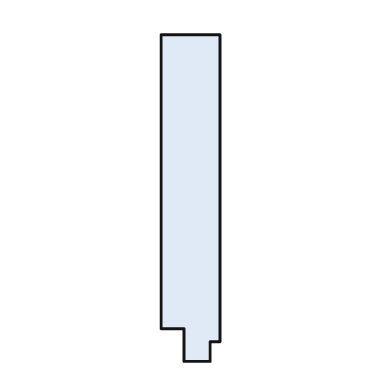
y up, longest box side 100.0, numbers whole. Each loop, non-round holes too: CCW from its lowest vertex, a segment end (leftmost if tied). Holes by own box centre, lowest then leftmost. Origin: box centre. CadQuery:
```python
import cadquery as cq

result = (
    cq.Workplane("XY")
    .moveTo(-2.0, -50.0)
    .lineTo(6.0, -50.0)
    .lineTo(6.0, -44.0)
    .lineTo(9.0, -44.0)
    .lineTo(9.0, 50.0)
    .lineTo(-9.0, 50.0)
    .lineTo(-9.0, -40.0)
    .lineTo(-2.0, -40.0)
    .close()
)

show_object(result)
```